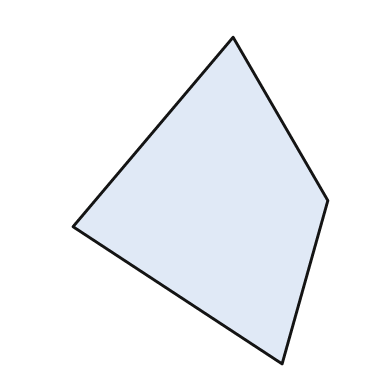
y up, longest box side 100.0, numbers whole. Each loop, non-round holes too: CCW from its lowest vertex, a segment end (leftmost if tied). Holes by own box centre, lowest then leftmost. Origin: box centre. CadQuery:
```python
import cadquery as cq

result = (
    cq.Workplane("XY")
    .moveTo(25.0, -50.0)
    .lineTo(39.0, 0.0)
    .lineTo(10.0, 50.0)
    .lineTo(-39.0, -8.0)
    .close()
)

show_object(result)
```